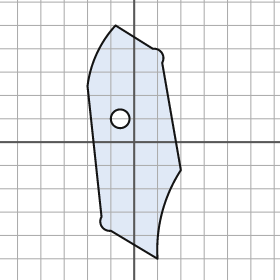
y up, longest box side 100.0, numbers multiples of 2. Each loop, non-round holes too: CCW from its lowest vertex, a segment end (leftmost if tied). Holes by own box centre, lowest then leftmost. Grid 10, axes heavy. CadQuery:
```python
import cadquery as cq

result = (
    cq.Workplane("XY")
    .moveTo(10.0, -50.0)
    .threePointArc((12.0, -30.0), (20.0, -12.0))
    .lineTo(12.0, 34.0)
    .threePointArc((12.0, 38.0), (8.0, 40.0))
    .lineTo(-8.0, 50.0)
    .threePointArc((-16.0, 38.0), (-20.0, 24.0))
    .lineTo(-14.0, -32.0)
    .threePointArc((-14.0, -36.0), (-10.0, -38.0))
    .close()
    .moveTo(-6.0, 10.0)
    .circle(4.0)
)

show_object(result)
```